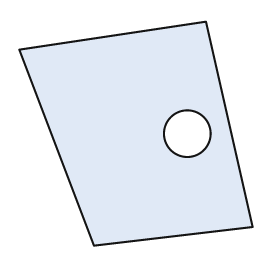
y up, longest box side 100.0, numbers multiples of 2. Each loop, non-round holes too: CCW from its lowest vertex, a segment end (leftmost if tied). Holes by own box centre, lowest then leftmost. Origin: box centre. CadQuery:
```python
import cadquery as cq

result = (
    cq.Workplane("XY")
    .moveTo(-18.0, -48.0)
    .lineTo(50.0, -40.0)
    .lineTo(30.0, 48.0)
    .lineTo(-50.0, 36.0)
    .close()
    .moveTo(22.0, 0.0)
    .circle(10.0)
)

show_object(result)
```